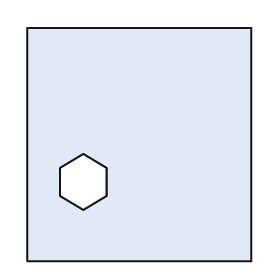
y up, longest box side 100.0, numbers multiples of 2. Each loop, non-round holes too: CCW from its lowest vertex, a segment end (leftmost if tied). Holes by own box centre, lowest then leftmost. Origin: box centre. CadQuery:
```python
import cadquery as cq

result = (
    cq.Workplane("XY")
    .moveTo(-48.0, -50.0)
    .lineTo(48.0, -50.0)
    .lineTo(48.0, 50.0)
    .lineTo(-48.0, 50.0)
    .close()
    .moveTo(-24.0, -28.0)
    .lineTo(-14.0, -22.0)
    .lineTo(-14.0, -10.0)
    .lineTo(-24.0, -4.0)
    .lineTo(-34.0, -10.0)
    .lineTo(-34.0, -22.0)
    .close()
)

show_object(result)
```